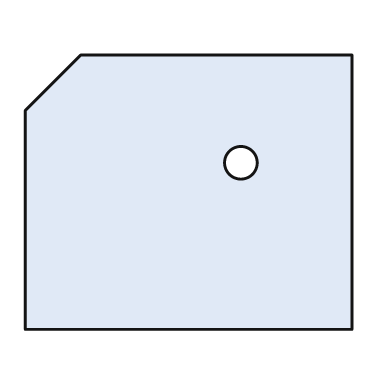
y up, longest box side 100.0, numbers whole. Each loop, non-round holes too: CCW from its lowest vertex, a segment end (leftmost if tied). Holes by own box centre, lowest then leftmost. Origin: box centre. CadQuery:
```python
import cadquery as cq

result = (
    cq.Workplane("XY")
    .moveTo(-50.0, -42.0)
    .lineTo(50.0, -42.0)
    .lineTo(50.0, 42.0)
    .lineTo(-33.0, 42.0)
    .lineTo(-50.0, 25.0)
    .close()
    .moveTo(16.0, 9.0)
    .circle(5.0)
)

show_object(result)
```